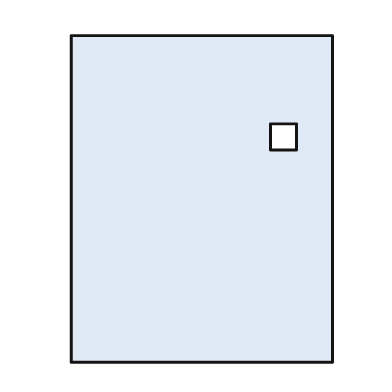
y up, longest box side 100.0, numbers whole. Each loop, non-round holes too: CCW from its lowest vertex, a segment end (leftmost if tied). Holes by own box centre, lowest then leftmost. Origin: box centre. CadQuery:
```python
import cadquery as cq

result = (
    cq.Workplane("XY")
    .moveTo(-40.0, -50.0)
    .lineTo(40.0, -50.0)
    .lineTo(40.0, 50.0)
    .lineTo(-40.0, 50.0)
    .close()
    .moveTo(21.0, 15.0)
    .lineTo(29.0, 15.0)
    .lineTo(29.0, 23.0)
    .lineTo(21.0, 23.0)
    .close()
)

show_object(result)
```